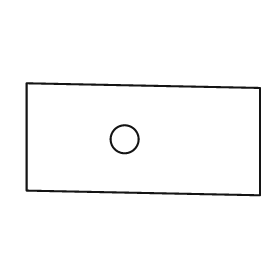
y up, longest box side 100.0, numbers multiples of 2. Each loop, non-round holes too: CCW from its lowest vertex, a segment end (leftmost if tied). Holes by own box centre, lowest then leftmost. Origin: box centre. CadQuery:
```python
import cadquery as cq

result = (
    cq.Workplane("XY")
    .moveTo(50.0, -24.0)
    .lineTo(50.0, 22.0)
    .lineTo(-50.0, 24.0)
    .lineTo(-50.0, -22.0)
    .close()
    .moveTo(-8.0, 0.0)
    .circle(6.0)
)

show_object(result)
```